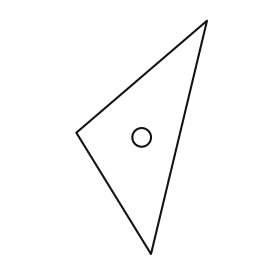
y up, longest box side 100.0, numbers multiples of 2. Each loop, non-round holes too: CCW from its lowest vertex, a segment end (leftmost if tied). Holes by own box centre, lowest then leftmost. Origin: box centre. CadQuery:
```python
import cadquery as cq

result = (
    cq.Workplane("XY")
    .moveTo(4.0, -50.0)
    .lineTo(28.0, 50.0)
    .lineTo(-28.0, 2.0)
    .close()
    .moveTo(0.0, 0.0)
    .circle(4.0)
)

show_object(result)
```